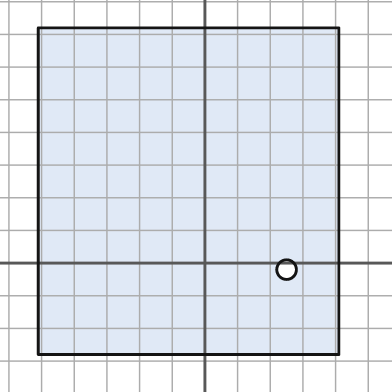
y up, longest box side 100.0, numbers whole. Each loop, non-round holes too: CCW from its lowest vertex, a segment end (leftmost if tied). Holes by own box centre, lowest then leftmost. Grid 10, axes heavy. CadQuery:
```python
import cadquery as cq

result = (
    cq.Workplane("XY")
    .moveTo(-51.0, -28.0)
    .lineTo(41.0, -28.0)
    .lineTo(41.0, 72.0)
    .lineTo(-51.0, 72.0)
    .close()
    .moveTo(25.0, -2.0)
    .circle(3.0)
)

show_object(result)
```